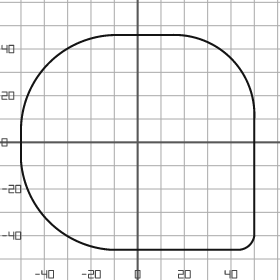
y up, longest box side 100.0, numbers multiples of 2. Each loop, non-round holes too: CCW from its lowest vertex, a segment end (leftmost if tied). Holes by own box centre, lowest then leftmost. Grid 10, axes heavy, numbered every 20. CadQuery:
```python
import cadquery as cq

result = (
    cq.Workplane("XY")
    .moveTo(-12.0, -46.0)
    .lineTo(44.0, -46.0)
    .threePointArc((48.0, -44.0), (50.0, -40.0))
    .lineTo(50.0, 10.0)
    .threePointArc((40.0, 36.0), (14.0, 46.0))
    .lineTo(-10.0, 46.0)
    .threePointArc((-38.0, 34.0), (-50.0, 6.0))
    .lineTo(-50.0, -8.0)
    .threePointArc((-38.0, -34.0), (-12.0, -46.0))
    .close()
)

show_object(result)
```